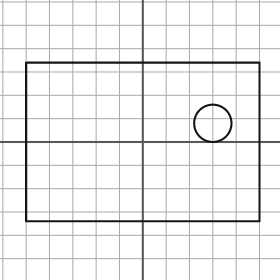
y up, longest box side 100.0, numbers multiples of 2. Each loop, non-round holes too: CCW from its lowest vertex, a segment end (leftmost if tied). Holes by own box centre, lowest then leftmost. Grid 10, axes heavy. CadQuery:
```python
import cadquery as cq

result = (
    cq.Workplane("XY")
    .moveTo(-50.0, -34.0)
    .lineTo(50.0, -34.0)
    .lineTo(50.0, 34.0)
    .lineTo(-50.0, 34.0)
    .close()
    .moveTo(30.0, 8.0)
    .circle(8.0)
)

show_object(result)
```